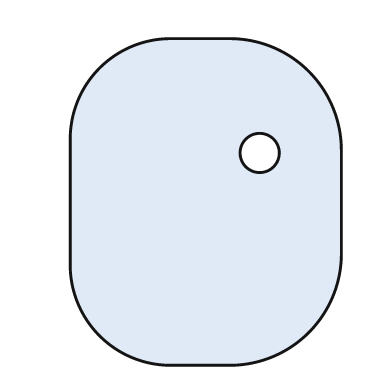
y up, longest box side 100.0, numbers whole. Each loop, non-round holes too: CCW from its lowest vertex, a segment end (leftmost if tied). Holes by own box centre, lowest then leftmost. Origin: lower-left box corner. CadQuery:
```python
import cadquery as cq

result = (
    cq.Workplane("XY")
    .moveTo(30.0, 0.0)
    .lineTo(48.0, 0.0)
    .threePointArc((73.0, 10.0), (83.0, 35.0))
    .lineTo(83.0, 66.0)
    .threePointArc((73.0, 90.0), (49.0, 100.0))
    .lineTo(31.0, 100.0)
    .threePointArc((9.0, 91.0), (0.0, 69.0))
    .lineTo(0.0, 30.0)
    .threePointArc((9.0, 9.0), (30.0, 0.0))
    .close()
    .moveTo(58.0, 65.0)
    .circle(6.0)
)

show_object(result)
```